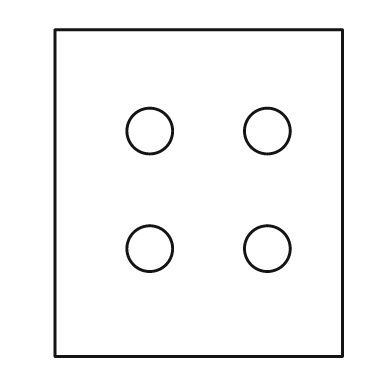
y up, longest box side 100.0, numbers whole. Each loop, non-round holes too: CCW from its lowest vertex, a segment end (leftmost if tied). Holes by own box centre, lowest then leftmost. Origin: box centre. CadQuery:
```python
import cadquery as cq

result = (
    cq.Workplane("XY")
    .moveTo(-44.0, -50.0)
    .lineTo(44.0, -50.0)
    .lineTo(44.0, 50.0)
    .lineTo(-44.0, 50.0)
    .close()
    .moveTo(-15.0, -17.0)
    .circle(7.0)
    .moveTo(21.0, -17.0)
    .circle(7.0)
    .moveTo(-15.0, 19.0)
    .circle(7.0)
    .moveTo(21.0, 19.0)
    .circle(7.0)
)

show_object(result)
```